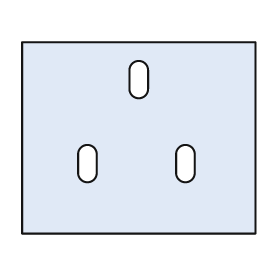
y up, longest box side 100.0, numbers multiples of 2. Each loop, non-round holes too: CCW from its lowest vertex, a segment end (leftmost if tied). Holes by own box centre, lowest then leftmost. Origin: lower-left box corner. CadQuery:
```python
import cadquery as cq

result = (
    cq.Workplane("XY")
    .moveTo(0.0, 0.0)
    .lineTo(100.0, 0.0)
    .lineTo(100.0, 82.0)
    .lineTo(0.0, 82.0)
    .close()
    .moveTo(24.0, 26.0)
    .threePointArc((28.0, 22.0), (32.0, 26.0))
    .lineTo(32.0, 34.0)
    .threePointArc((28.0, 38.0), (24.0, 34.0))
    .close()
    .moveTo(66.0, 26.0)
    .threePointArc((70.0, 22.0), (74.0, 26.0))
    .lineTo(74.0, 34.0)
    .threePointArc((70.0, 38.0), (66.0, 34.0))
    .close()
    .moveTo(46.0, 62.0)
    .threePointArc((50.0, 58.0), (54.0, 62.0))
    .lineTo(54.0, 70.0)
    .threePointArc((50.0, 74.0), (46.0, 70.0))
    .close()
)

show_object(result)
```